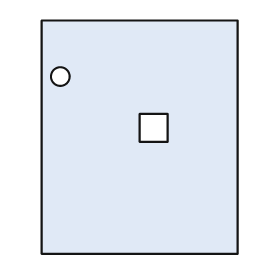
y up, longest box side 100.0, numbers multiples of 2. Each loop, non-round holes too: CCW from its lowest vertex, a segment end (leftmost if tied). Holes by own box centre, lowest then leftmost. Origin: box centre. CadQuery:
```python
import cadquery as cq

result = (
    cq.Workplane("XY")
    .moveTo(-42.0, -50.0)
    .lineTo(42.0, -50.0)
    .lineTo(42.0, 50.0)
    .lineTo(-42.0, 50.0)
    .close()
    .moveTo(0.0, -2.0)
    .lineTo(12.0, -2.0)
    .lineTo(12.0, 10.0)
    .lineTo(0.0, 10.0)
    .close()
    .moveTo(-34.0, 26.0)
    .circle(4.0)
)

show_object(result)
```